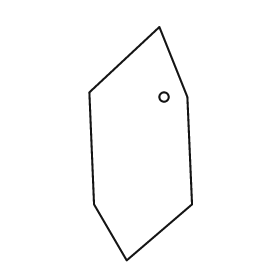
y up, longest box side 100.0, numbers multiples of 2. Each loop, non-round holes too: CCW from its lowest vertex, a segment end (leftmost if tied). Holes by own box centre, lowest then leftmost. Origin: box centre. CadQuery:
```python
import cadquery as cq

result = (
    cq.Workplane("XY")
    .moveTo(-6.0, -50.0)
    .lineTo(22.0, -26.0)
    .lineTo(20.0, 20.0)
    .lineTo(8.0, 50.0)
    .lineTo(-22.0, 22.0)
    .lineTo(-20.0, -26.0)
    .close()
    .moveTo(10.0, 20.0)
    .circle(2.0)
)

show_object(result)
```